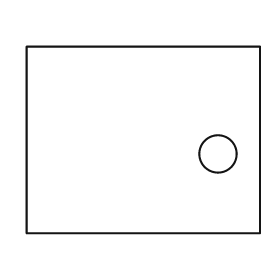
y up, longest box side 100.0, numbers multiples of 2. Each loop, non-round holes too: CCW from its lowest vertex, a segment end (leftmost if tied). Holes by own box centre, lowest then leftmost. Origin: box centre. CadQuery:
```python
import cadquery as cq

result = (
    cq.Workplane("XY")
    .moveTo(-50.0, -40.0)
    .lineTo(50.0, -40.0)
    .lineTo(50.0, 40.0)
    .lineTo(-50.0, 40.0)
    .close()
    .moveTo(32.0, -6.0)
    .circle(8.0)
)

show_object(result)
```